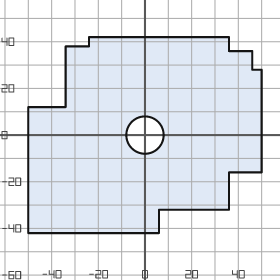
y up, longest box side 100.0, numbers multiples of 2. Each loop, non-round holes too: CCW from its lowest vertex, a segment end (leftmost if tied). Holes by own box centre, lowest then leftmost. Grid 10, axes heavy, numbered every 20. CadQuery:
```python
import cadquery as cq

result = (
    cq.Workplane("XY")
    .moveTo(-50.0, -42.0)
    .lineTo(6.0, -42.0)
    .lineTo(6.0, -32.0)
    .lineTo(36.0, -32.0)
    .lineTo(36.0, -16.0)
    .lineTo(50.0, -16.0)
    .lineTo(50.0, 28.0)
    .lineTo(46.0, 28.0)
    .lineTo(46.0, 36.0)
    .lineTo(36.0, 36.0)
    .lineTo(36.0, 42.0)
    .lineTo(-24.0, 42.0)
    .lineTo(-24.0, 38.0)
    .lineTo(-34.0, 38.0)
    .lineTo(-34.0, 12.0)
    .lineTo(-50.0, 12.0)
    .close()
    .moveTo(0.0, 0.0)
    .circle(8.0)
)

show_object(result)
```